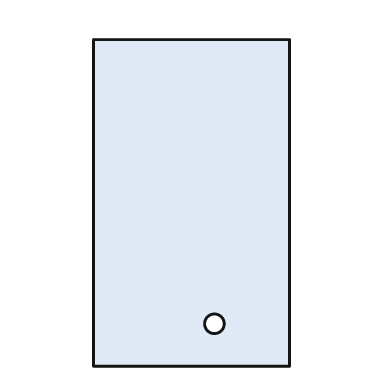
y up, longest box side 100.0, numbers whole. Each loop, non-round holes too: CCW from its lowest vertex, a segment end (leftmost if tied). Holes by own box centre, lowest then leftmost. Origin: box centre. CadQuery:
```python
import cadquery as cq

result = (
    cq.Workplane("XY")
    .moveTo(-30.0, -50.0)
    .lineTo(30.0, -50.0)
    .lineTo(30.0, 50.0)
    .lineTo(-30.0, 50.0)
    .close()
    .moveTo(7.0, -37.0)
    .circle(3.0)
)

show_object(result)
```